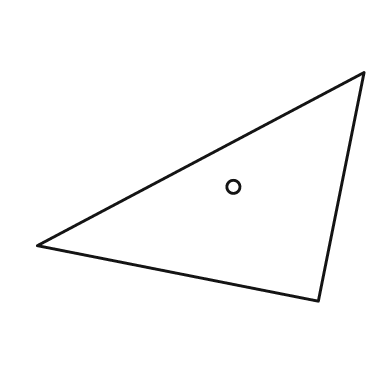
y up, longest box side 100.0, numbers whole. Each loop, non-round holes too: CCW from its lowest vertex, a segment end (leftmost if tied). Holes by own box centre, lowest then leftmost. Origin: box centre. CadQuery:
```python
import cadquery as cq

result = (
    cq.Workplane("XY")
    .moveTo(36.0, -35.0)
    .lineTo(50.0, 35.0)
    .lineTo(-50.0, -18.0)
    .close()
    .moveTo(10.0, 0.0)
    .circle(2.0)
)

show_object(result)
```